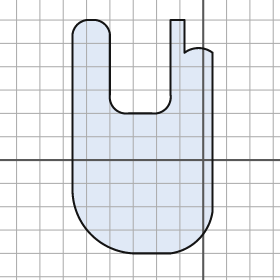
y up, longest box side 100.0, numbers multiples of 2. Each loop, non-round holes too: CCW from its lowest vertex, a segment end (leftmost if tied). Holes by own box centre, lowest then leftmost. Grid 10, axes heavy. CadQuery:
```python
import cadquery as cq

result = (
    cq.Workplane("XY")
    .moveTo(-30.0, -40.0)
    .lineTo(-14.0, -40.0)
    .threePointArc((-2.0, -34.0), (4.0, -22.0))
    .lineTo(4.0, 46.0)
    .threePointArc((-2.0, 48.0), (-8.0, 46.0))
    .lineTo(-8.0, 60.0)
    .lineTo(-14.0, 60.0)
    .lineTo(-14.0, 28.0)
    .threePointArc((-16.0, 22.0), (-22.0, 20.0))
    .lineTo(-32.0, 20.0)
    .threePointArc((-38.0, 22.0), (-40.0, 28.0))
    .lineTo(-40.0, 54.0)
    .threePointArc((-42.0, 58.0), (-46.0, 60.0))
    .lineTo(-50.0, 60.0)
    .threePointArc((-54.0, 58.0), (-56.0, 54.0))
    .lineTo(-56.0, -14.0)
    .threePointArc((-48.0, -32.0), (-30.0, -40.0))
    .close()
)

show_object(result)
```